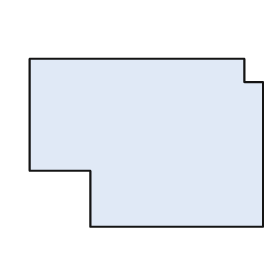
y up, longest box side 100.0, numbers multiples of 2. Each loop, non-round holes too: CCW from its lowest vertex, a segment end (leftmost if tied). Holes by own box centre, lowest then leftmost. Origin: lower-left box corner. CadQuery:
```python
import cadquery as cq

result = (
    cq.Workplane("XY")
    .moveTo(26.0, 0.0)
    .lineTo(100.0, 0.0)
    .lineTo(100.0, 62.0)
    .lineTo(92.0, 62.0)
    .lineTo(92.0, 72.0)
    .lineTo(0.0, 72.0)
    .lineTo(0.0, 24.0)
    .lineTo(26.0, 24.0)
    .close()
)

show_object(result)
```